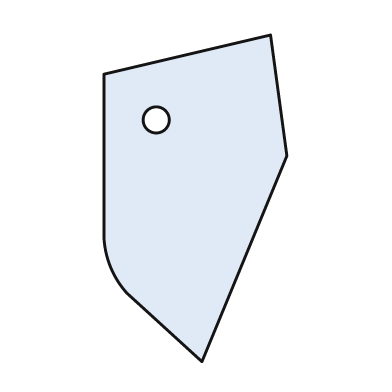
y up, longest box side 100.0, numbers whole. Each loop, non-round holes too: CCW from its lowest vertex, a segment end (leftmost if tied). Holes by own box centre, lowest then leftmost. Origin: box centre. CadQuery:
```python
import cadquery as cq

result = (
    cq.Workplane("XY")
    .moveTo(2.0, -50.0)
    .lineTo(28.0, 13.0)
    .lineTo(23.0, 50.0)
    .lineTo(-28.0, 38.0)
    .lineTo(-28.0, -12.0)
    .threePointArc((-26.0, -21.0), (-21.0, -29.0))
    .close()
    .moveTo(-12.0, 24.0)
    .circle(4.0)
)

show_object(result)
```